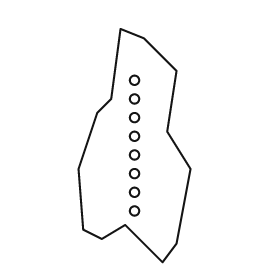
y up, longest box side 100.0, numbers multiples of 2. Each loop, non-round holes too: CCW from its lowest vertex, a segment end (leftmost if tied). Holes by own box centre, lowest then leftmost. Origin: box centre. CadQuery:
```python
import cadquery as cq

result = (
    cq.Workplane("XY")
    .moveTo(12.0, -50.0)
    .lineTo(18.0, -42.0)
    .lineTo(24.0, -10.0)
    .lineTo(14.0, 6.0)
    .lineTo(18.0, 32.0)
    .lineTo(4.0, 46.0)
    .lineTo(-6.0, 50.0)
    .lineTo(-10.0, 20.0)
    .lineTo(-16.0, 14.0)
    .lineTo(-24.0, -10.0)
    .lineTo(-22.0, -36.0)
    .lineTo(-14.0, -40.0)
    .lineTo(-4.0, -34.0)
    .close()
    .moveTo(0.0, -28.0)
    .circle(2.0)
    .moveTo(0.0, -20.0)
    .circle(2.0)
    .moveTo(0.0, -12.0)
    .circle(2.0)
    .moveTo(0.0, -4.0)
    .circle(2.0)
    .moveTo(0.0, 4.0)
    .circle(2.0)
    .moveTo(0.0, 12.0)
    .circle(2.0)
    .moveTo(0.0, 20.0)
    .circle(2.0)
    .moveTo(0.0, 28.0)
    .circle(2.0)
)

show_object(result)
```